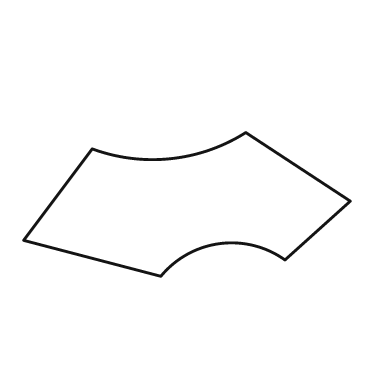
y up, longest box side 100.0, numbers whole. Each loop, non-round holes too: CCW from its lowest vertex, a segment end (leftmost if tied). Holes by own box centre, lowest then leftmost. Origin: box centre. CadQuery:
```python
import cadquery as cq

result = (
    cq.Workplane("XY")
    .moveTo(-8.0, -22.0)
    .threePointArc((10.0, -12.0), (30.0, -17.0))
    .lineTo(50.0, 1.0)
    .lineTo(18.0, 22.0)
    .threePointArc((-5.0, 14.0), (-29.0, 17.0))
    .lineTo(-50.0, -11.0)
    .close()
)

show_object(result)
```